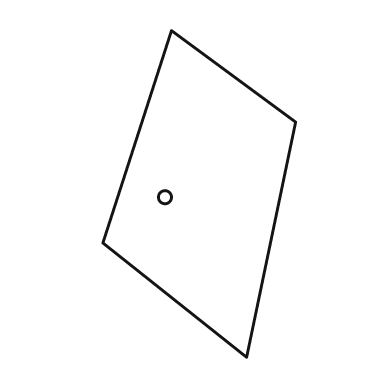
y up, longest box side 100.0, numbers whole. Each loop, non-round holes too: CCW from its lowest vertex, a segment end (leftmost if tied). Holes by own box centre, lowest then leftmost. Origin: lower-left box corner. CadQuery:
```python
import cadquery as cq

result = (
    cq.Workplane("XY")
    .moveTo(44.0, 0.0)
    .lineTo(59.0, 72.0)
    .lineTo(21.0, 100.0)
    .lineTo(0.0, 35.0)
    .close()
    .moveTo(19.0, 49.0)
    .circle(2.0)
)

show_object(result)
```